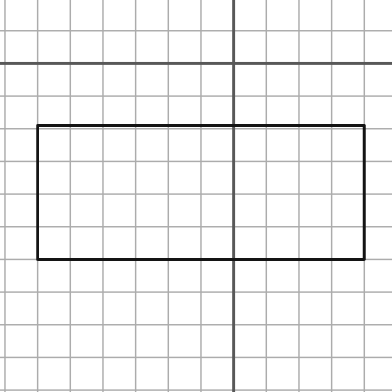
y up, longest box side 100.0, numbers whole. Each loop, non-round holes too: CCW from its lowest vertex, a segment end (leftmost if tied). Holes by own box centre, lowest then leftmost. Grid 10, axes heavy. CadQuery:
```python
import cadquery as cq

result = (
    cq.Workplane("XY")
    .moveTo(-60.0, -60.0)
    .lineTo(40.0, -60.0)
    .lineTo(40.0, -19.0)
    .lineTo(-60.0, -19.0)
    .close()
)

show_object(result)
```